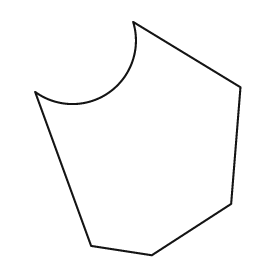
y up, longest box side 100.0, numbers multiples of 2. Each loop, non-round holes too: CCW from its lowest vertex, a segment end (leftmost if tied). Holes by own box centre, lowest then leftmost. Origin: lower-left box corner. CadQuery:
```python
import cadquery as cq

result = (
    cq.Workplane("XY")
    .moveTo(50.0, 0.0)
    .lineTo(84.0, 22.0)
    .lineTo(88.0, 72.0)
    .lineTo(42.0, 100.0)
    .threePointArc((32.0, 70.0), (0.0, 70.0))
    .lineTo(24.0, 4.0)
    .close()
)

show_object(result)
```